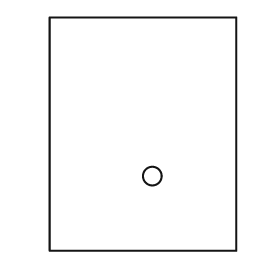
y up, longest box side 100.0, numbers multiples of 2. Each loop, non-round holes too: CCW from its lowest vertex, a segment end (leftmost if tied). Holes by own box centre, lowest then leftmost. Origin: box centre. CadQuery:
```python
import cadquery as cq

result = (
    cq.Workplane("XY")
    .moveTo(-40.0, -50.0)
    .lineTo(40.0, -50.0)
    .lineTo(40.0, 50.0)
    .lineTo(-40.0, 50.0)
    .close()
    .moveTo(4.0, -18.0)
    .circle(4.0)
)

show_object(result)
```